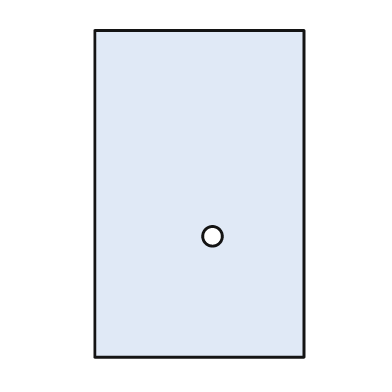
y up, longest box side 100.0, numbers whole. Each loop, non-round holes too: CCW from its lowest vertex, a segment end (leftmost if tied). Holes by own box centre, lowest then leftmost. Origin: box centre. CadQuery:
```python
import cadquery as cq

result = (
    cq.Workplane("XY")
    .moveTo(-32.0, -50.0)
    .lineTo(32.0, -50.0)
    .lineTo(32.0, 50.0)
    .lineTo(-32.0, 50.0)
    .close()
    .moveTo(4.0, -13.0)
    .circle(3.0)
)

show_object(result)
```